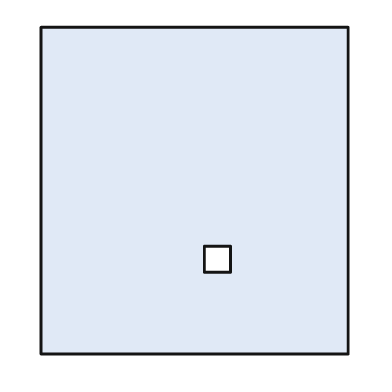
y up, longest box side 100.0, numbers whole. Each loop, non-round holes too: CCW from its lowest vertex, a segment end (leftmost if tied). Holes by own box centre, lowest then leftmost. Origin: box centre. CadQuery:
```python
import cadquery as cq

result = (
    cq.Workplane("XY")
    .moveTo(-47.0, -50.0)
    .lineTo(47.0, -50.0)
    .lineTo(47.0, 50.0)
    .lineTo(-47.0, 50.0)
    .close()
    .moveTo(3.0, -25.0)
    .lineTo(11.0, -25.0)
    .lineTo(11.0, -17.0)
    .lineTo(3.0, -17.0)
    .close()
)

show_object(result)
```